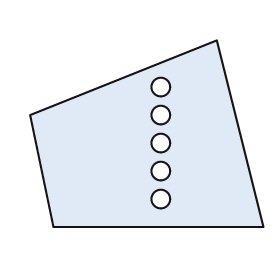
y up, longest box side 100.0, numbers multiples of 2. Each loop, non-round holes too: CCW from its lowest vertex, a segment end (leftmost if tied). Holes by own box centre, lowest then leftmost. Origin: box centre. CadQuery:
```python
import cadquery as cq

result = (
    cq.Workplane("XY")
    .moveTo(-40.0, -40.0)
    .lineTo(50.0, -40.0)
    .lineTo(30.0, 40.0)
    .lineTo(-50.0, 8.0)
    .close()
    .moveTo(6.0, -28.0)
    .circle(4.0)
    .moveTo(6.0, -16.0)
    .circle(4.0)
    .moveTo(6.0, -4.0)
    .circle(4.0)
    .moveTo(6.0, 8.0)
    .circle(4.0)
    .moveTo(6.0, 20.0)
    .circle(4.0)
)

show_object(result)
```